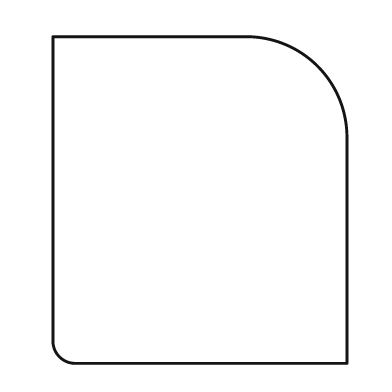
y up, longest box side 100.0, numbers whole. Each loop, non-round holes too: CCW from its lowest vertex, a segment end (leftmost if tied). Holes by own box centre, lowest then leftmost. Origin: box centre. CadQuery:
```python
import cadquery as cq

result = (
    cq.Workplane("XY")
    .moveTo(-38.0, -50.0)
    .lineTo(45.0, -50.0)
    .lineTo(45.0, 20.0)
    .threePointArc((36.0, 41.0), (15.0, 50.0))
    .lineTo(-45.0, 50.0)
    .lineTo(-45.0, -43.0)
    .threePointArc((-43.0, -48.0), (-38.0, -50.0))
    .close()
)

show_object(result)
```